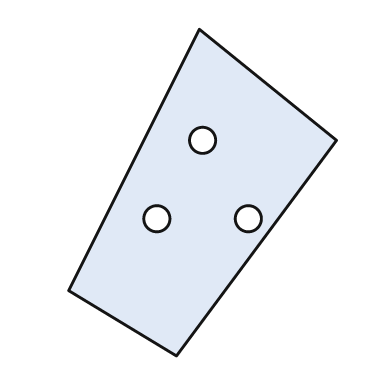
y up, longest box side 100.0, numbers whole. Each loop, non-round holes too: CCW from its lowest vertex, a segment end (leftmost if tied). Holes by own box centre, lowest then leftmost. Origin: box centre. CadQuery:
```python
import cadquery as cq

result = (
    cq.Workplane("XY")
    .moveTo(-8.0, -50.0)
    .lineTo(41.0, 16.0)
    .lineTo(-1.0, 50.0)
    .lineTo(-41.0, -30.0)
    .close()
    .moveTo(-14.0, -8.0)
    .circle(4.0)
    .moveTo(14.0, -8.0)
    .circle(4.0)
    .moveTo(0.0, 16.0)
    .circle(4.0)
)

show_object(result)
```